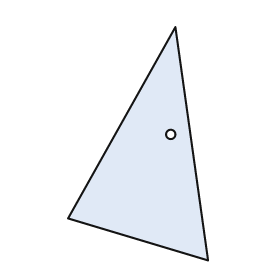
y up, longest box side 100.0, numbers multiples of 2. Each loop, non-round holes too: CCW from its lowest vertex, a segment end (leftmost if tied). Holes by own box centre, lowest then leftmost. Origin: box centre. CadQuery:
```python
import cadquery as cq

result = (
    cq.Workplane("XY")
    .moveTo(30.0, -50.0)
    .lineTo(16.0, 50.0)
    .lineTo(-30.0, -32.0)
    .close()
    .moveTo(14.0, 4.0)
    .circle(2.0)
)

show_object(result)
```